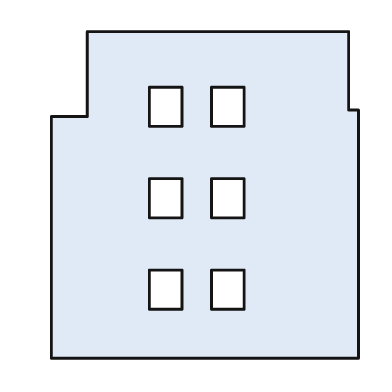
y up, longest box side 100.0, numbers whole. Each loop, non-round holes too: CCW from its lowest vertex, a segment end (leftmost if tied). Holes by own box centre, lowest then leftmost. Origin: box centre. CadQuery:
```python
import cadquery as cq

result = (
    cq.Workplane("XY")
    .moveTo(-47.0, -50.0)
    .lineTo(47.0, -50.0)
    .lineTo(47.0, 26.0)
    .lineTo(44.0, 26.0)
    .lineTo(44.0, 50.0)
    .lineTo(-36.0, 50.0)
    .lineTo(-36.0, 24.0)
    .lineTo(-47.0, 24.0)
    .close()
    .moveTo(-17.0, -35.0)
    .lineTo(-7.0, -35.0)
    .lineTo(-7.0, -23.0)
    .lineTo(-17.0, -23.0)
    .close()
    .moveTo(2.0, -35.0)
    .lineTo(12.0, -35.0)
    .lineTo(12.0, -23.0)
    .lineTo(2.0, -23.0)
    .close()
    .moveTo(-17.0, -7.0)
    .lineTo(-7.0, -7.0)
    .lineTo(-7.0, 5.0)
    .lineTo(-17.0, 5.0)
    .close()
    .moveTo(2.0, -7.0)
    .lineTo(12.0, -7.0)
    .lineTo(12.0, 5.0)
    .lineTo(2.0, 5.0)
    .close()
    .moveTo(-17.0, 21.0)
    .lineTo(-7.0, 21.0)
    .lineTo(-7.0, 33.0)
    .lineTo(-17.0, 33.0)
    .close()
    .moveTo(2.0, 21.0)
    .lineTo(12.0, 21.0)
    .lineTo(12.0, 33.0)
    .lineTo(2.0, 33.0)
    .close()
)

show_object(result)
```